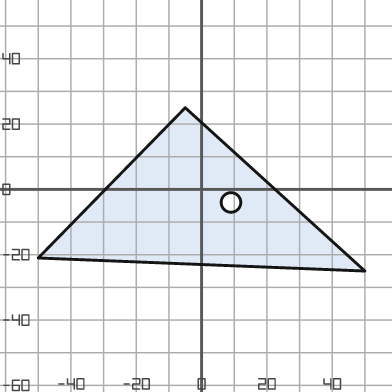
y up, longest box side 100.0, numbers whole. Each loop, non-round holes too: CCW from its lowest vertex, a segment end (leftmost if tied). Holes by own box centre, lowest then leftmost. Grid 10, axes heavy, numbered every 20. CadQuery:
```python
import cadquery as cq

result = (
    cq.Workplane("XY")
    .moveTo(50.0, -25.0)
    .lineTo(-5.0, 25.0)
    .lineTo(-50.0, -21.0)
    .close()
    .moveTo(9.0, -4.0)
    .circle(3.0)
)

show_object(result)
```